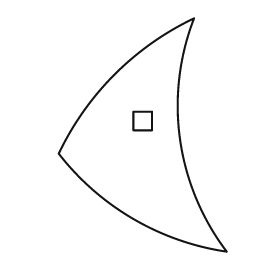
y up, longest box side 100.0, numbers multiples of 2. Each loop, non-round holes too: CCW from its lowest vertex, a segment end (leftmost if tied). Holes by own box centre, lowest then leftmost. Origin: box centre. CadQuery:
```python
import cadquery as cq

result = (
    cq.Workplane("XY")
    .moveTo(36.0, -50.0)
    .threePointArc((16.0, -2.0), (22.0, 50.0))
    .threePointArc((-12.0, 26.0), (-36.0, -8.0))
    .threePointArc((-4.0, -36.0), (36.0, -50.0))
    .close()
    .moveTo(-4.0, 2.0)
    .lineTo(4.0, 2.0)
    .lineTo(4.0, 10.0)
    .lineTo(-4.0, 10.0)
    .close()
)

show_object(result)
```